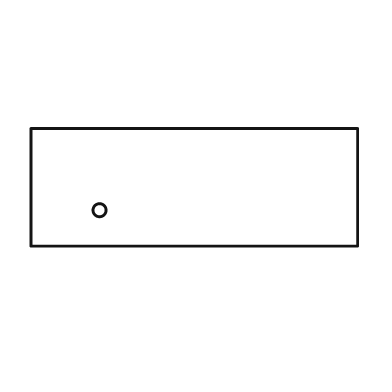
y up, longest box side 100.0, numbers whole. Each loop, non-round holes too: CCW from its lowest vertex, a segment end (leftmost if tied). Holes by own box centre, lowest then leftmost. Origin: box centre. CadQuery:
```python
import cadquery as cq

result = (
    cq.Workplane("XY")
    .moveTo(-50.0, -18.0)
    .lineTo(50.0, -18.0)
    .lineTo(50.0, 18.0)
    .lineTo(-50.0, 18.0)
    .close()
    .moveTo(-29.0, -7.0)
    .circle(2.0)
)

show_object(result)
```